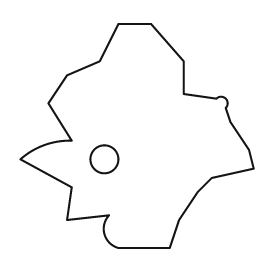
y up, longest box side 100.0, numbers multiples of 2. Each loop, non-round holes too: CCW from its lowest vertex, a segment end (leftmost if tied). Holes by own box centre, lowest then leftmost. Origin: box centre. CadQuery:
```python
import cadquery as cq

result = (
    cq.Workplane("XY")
    .moveTo(-8.0, -48.0)
    .lineTo(14.0, -48.0)
    .lineTo(18.0, -36.0)
    .lineTo(26.0, -24.0)
    .lineTo(32.0, -18.0)
    .lineTo(50.0, -14.0)
    .lineTo(48.0, -6.0)
    .lineTo(40.0, 6.0)
    .lineTo(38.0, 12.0)
    .threePointArc((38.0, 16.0), (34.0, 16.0))
    .lineTo(20.0, 18.0)
    .lineTo(20.0, 32.0)
    .lineTo(6.0, 48.0)
    .lineTo(-8.0, 48.0)
    .lineTo(-16.0, 32.0)
    .lineTo(-30.0, 26.0)
    .lineTo(-38.0, 14.0)
    .lineTo(-28.0, -2.0)
    .threePointArc((-40.0, -4.0), (-50.0, -10.0))
    .lineTo(-28.0, -22.0)
    .lineTo(-30.0, -36.0)
    .lineTo(-12.0, -34.0)
    .threePointArc((-14.0, -42.0), (-8.0, -48.0))
    .close()
    .moveTo(-14.0, -10.0)
    .circle(6.0)
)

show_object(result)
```